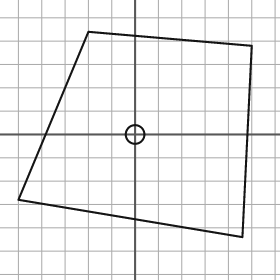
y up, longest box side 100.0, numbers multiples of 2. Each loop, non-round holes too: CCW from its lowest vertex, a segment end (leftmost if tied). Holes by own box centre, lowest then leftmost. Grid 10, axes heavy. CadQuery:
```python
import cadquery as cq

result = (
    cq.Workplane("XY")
    .moveTo(46.0, -44.0)
    .lineTo(50.0, 38.0)
    .lineTo(-20.0, 44.0)
    .lineTo(-50.0, -28.0)
    .close()
    .moveTo(0.0, 0.0)
    .circle(4.0)
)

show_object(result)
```